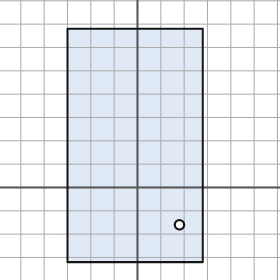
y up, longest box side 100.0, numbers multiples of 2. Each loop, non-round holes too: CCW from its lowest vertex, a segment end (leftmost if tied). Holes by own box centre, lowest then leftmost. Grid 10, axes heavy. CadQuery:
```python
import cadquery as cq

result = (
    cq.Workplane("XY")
    .moveTo(-30.0, -32.0)
    .lineTo(28.0, -32.0)
    .lineTo(28.0, 68.0)
    .lineTo(-30.0, 68.0)
    .close()
    .moveTo(18.0, -16.0)
    .circle(2.0)
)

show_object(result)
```